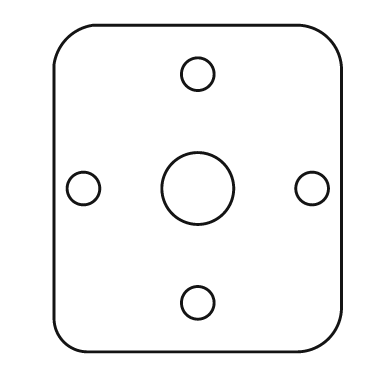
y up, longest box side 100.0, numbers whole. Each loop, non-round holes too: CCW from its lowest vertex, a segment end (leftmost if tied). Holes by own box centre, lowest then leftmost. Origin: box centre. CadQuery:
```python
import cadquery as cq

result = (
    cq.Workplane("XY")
    .moveTo(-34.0, -50.0)
    .lineTo(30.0, -50.0)
    .threePointArc((40.0, -46.0), (44.0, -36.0))
    .lineTo(44.0, 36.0)
    .threePointArc((40.0, 46.0), (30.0, 50.0))
    .lineTo(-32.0, 50.0)
    .threePointArc((-40.0, 46.0), (-44.0, 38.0))
    .lineTo(-44.0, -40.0)
    .threePointArc((-41.0, -47.0), (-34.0, -50.0))
    .close()
    .moveTo(0.0, -35.0)
    .circle(5.0)
    .moveTo(-35.0, 0.0)
    .circle(5.0)
    .moveTo(0.0, 0.0)
    .circle(11.0)
    .moveTo(35.0, 0.0)
    .circle(5.0)
    .moveTo(0.0, 35.0)
    .circle(5.0)
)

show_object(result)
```